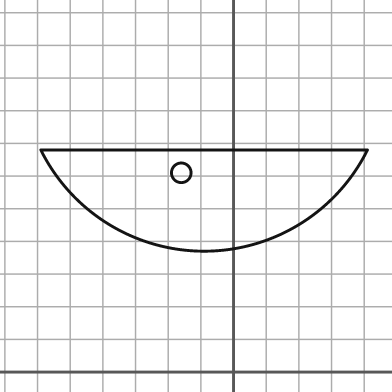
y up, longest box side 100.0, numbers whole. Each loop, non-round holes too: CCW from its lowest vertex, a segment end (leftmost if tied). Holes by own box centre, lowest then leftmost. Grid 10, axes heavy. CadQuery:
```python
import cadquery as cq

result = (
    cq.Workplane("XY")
    .moveTo(-59.0, 68.0)
    .threePointArc((-9.0, 37.0), (41.0, 68.0))
    .close()
    .moveTo(-16.0, 61.0)
    .circle(3.0)
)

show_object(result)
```